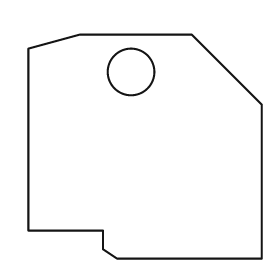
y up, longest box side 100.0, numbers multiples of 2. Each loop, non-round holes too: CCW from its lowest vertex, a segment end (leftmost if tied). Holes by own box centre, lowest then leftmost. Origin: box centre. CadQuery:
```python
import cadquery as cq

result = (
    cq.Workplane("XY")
    .moveTo(-12.0, -48.0)
    .lineTo(50.0, -48.0)
    .lineTo(50.0, 18.0)
    .lineTo(20.0, 48.0)
    .lineTo(-28.0, 48.0)
    .lineTo(-50.0, 42.0)
    .lineTo(-50.0, -36.0)
    .lineTo(-18.0, -36.0)
    .lineTo(-18.0, -44.0)
    .close()
    .moveTo(-6.0, 32.0)
    .circle(10.0)
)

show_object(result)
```